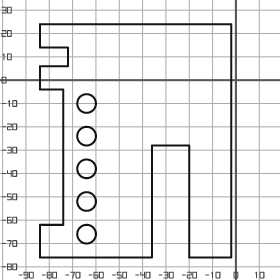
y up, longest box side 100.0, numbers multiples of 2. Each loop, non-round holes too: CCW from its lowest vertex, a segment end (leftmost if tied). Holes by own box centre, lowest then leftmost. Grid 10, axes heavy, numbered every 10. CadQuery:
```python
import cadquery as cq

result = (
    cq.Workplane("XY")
    .moveTo(-84.0, -76.0)
    .lineTo(-36.0, -76.0)
    .lineTo(-36.0, -28.0)
    .lineTo(-20.0, -28.0)
    .lineTo(-20.0, -76.0)
    .lineTo(-2.0, -76.0)
    .lineTo(-2.0, 24.0)
    .lineTo(-84.0, 24.0)
    .lineTo(-84.0, 14.0)
    .lineTo(-72.0, 14.0)
    .lineTo(-72.0, 6.0)
    .lineTo(-84.0, 6.0)
    .lineTo(-84.0, -4.0)
    .lineTo(-74.0, -4.0)
    .lineTo(-74.0, -62.0)
    .lineTo(-84.0, -62.0)
    .close()
    .moveTo(-64.0, -66.0)
    .circle(4.0)
    .moveTo(-64.0, -52.0)
    .circle(4.0)
    .moveTo(-64.0, -38.0)
    .circle(4.0)
    .moveTo(-64.0, -24.0)
    .circle(4.0)
    .moveTo(-64.0, -10.0)
    .circle(4.0)
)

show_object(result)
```